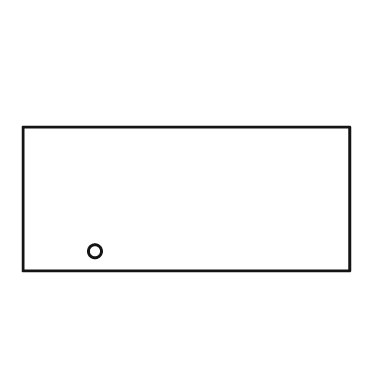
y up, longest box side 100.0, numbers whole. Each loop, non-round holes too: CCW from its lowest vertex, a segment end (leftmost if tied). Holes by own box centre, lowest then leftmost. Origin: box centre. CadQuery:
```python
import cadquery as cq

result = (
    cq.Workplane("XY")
    .moveTo(-50.0, -22.0)
    .lineTo(50.0, -22.0)
    .lineTo(50.0, 22.0)
    .lineTo(-50.0, 22.0)
    .close()
    .moveTo(-28.0, -16.0)
    .circle(2.0)
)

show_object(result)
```